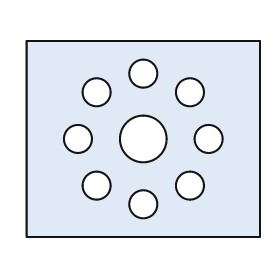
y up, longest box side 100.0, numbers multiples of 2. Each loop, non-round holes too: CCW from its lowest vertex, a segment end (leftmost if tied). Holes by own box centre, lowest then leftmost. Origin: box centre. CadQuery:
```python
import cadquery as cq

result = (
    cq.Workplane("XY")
    .moveTo(-50.0, -42.0)
    .lineTo(50.0, -42.0)
    .lineTo(50.0, 42.0)
    .lineTo(-50.0, 42.0)
    .close()
    .moveTo(0.0, -28.0)
    .circle(6.0)
    .moveTo(-20.0, -20.0)
    .circle(6.0)
    .moveTo(20.0, -20.0)
    .circle(6.0)
    .moveTo(-28.0, 0.0)
    .circle(6.0)
    .moveTo(0.0, 0.0)
    .circle(10.0)
    .moveTo(28.0, 0.0)
    .circle(6.0)
    .moveTo(-20.0, 20.0)
    .circle(6.0)
    .moveTo(20.0, 20.0)
    .circle(6.0)
    .moveTo(0.0, 28.0)
    .circle(6.0)
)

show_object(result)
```